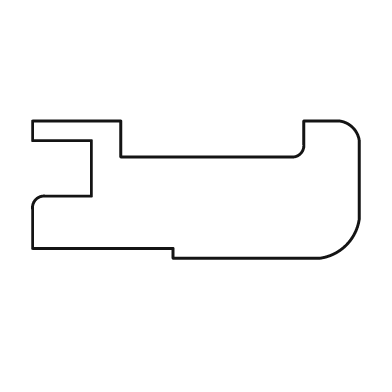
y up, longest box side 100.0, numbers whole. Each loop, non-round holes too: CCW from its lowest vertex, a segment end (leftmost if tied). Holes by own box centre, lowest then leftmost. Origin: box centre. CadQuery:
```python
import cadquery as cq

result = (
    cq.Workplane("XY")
    .moveTo(-7.0, -21.0)
    .lineTo(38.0, -21.0)
    .threePointArc((46.0, -17.0), (50.0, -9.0))
    .lineTo(50.0, 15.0)
    .threePointArc((48.0, 19.0), (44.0, 21.0))
    .lineTo(33.0, 21.0)
    .lineTo(33.0, 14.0)
    .threePointArc((32.0, 11.0), (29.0, 10.0))
    .lineTo(-23.0, 10.0)
    .lineTo(-23.0, 21.0)
    .lineTo(-50.0, 21.0)
    .lineTo(-50.0, 15.0)
    .lineTo(-32.0, 15.0)
    .lineTo(-32.0, -2.0)
    .lineTo(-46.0, -2.0)
    .threePointArc((-49.0, -3.0), (-50.0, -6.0))
    .lineTo(-50.0, -18.0)
    .lineTo(-7.0, -18.0)
    .close()
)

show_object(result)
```